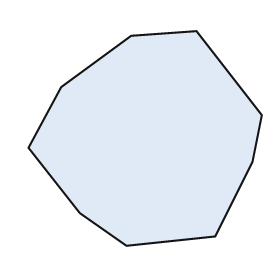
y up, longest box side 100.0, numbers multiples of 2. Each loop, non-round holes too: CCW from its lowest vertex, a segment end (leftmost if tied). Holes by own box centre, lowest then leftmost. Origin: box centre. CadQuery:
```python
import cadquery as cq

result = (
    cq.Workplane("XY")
    .moveTo(-8.0, -46.0)
    .lineTo(30.0, -42.0)
    .lineTo(46.0, -10.0)
    .lineTo(50.0, 10.0)
    .lineTo(22.0, 46.0)
    .lineTo(-6.0, 44.0)
    .lineTo(-36.0, 22.0)
    .lineTo(-50.0, -4.0)
    .lineTo(-28.0, -32.0)
    .close()
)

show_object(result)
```